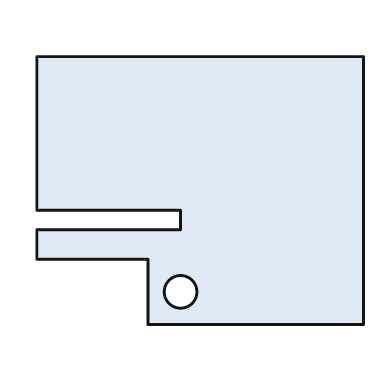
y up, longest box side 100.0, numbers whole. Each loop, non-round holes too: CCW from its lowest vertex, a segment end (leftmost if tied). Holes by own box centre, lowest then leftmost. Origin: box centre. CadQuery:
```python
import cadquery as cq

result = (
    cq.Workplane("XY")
    .moveTo(-16.0, -41.0)
    .lineTo(50.0, -41.0)
    .lineTo(50.0, 41.0)
    .lineTo(-50.0, 41.0)
    .lineTo(-50.0, -6.0)
    .lineTo(-6.0, -6.0)
    .lineTo(-6.0, -12.0)
    .lineTo(-50.0, -12.0)
    .lineTo(-50.0, -21.0)
    .lineTo(-16.0, -21.0)
    .close()
    .moveTo(-6.0, -31.0)
    .circle(5.0)
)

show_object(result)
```